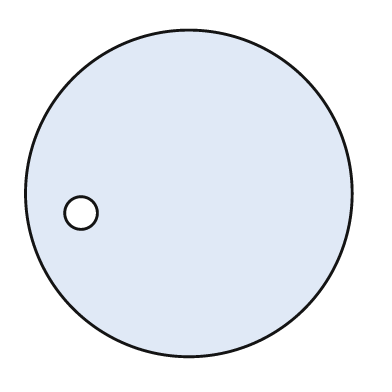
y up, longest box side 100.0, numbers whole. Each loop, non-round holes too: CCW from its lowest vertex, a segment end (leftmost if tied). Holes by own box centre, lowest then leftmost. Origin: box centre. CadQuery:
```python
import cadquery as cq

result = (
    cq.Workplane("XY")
    .moveTo(0.0, 0.0)
    .circle(50.0)
    .moveTo(-33.0, -6.0)
    .circle(5.0)
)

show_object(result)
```